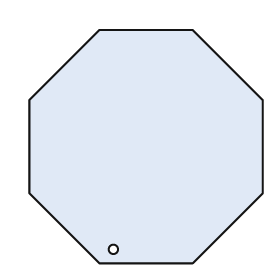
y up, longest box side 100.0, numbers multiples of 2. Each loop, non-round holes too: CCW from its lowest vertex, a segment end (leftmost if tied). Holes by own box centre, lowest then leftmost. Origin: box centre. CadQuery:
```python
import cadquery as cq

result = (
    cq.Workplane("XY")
    .moveTo(-20.0, -50.0)
    .lineTo(20.0, -50.0)
    .lineTo(50.0, -20.0)
    .lineTo(50.0, 20.0)
    .lineTo(20.0, 50.0)
    .lineTo(-20.0, 50.0)
    .lineTo(-50.0, 20.0)
    .lineTo(-50.0, -20.0)
    .close()
    .moveTo(-14.0, -44.0)
    .circle(2.0)
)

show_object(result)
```